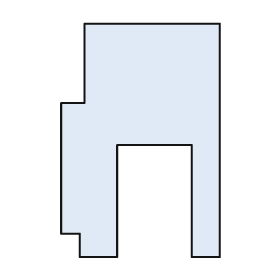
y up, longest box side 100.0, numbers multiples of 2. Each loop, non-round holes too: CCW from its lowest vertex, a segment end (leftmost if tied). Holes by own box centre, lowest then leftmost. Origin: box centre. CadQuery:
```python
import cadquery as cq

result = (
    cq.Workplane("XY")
    .moveTo(-26.0, -50.0)
    .lineTo(-10.0, -50.0)
    .lineTo(-10.0, -2.0)
    .lineTo(22.0, -2.0)
    .lineTo(22.0, -50.0)
    .lineTo(34.0, -50.0)
    .lineTo(34.0, 50.0)
    .lineTo(-24.0, 50.0)
    .lineTo(-24.0, 16.0)
    .lineTo(-34.0, 16.0)
    .lineTo(-34.0, -40.0)
    .lineTo(-26.0, -40.0)
    .close()
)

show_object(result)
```